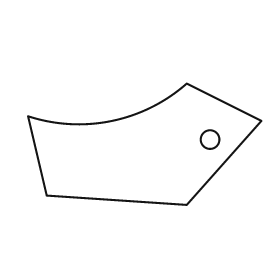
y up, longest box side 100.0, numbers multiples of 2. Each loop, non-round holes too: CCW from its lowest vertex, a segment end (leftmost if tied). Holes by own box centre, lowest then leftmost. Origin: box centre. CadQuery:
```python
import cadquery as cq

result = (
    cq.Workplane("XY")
    .moveTo(18.0, -26.0)
    .lineTo(50.0, 10.0)
    .lineTo(18.0, 26.0)
    .threePointArc((-14.0, 10.0), (-50.0, 12.0))
    .lineTo(-42.0, -22.0)
    .close()
    .moveTo(28.0, 2.0)
    .circle(4.0)
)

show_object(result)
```